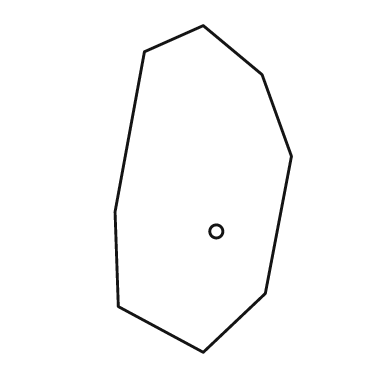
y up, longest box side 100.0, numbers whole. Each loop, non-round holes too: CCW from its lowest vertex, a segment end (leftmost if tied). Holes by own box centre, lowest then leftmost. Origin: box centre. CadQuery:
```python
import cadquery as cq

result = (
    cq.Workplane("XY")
    .moveTo(0.0, -50.0)
    .lineTo(19.0, -32.0)
    .lineTo(27.0, 10.0)
    .lineTo(18.0, 35.0)
    .lineTo(0.0, 50.0)
    .lineTo(-18.0, 42.0)
    .lineTo(-27.0, -7.0)
    .lineTo(-26.0, -36.0)
    .close()
    .moveTo(4.0, -13.0)
    .circle(2.0)
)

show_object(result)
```